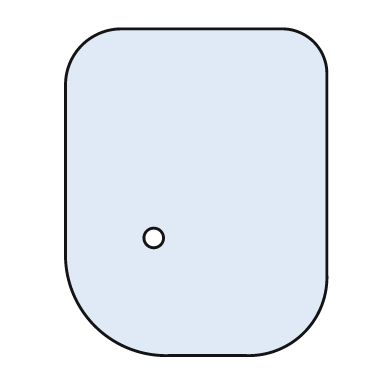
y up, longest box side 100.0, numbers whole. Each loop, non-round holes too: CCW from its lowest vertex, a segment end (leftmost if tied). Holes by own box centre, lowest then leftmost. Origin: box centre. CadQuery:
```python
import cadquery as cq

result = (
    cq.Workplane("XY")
    .moveTo(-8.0, -50.0)
    .lineTo(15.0, -50.0)
    .threePointArc((33.0, -43.0), (40.0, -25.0))
    .lineTo(40.0, 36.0)
    .threePointArc((36.0, 46.0), (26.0, 50.0))
    .lineTo(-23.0, 50.0)
    .threePointArc((-35.0, 45.0), (-40.0, 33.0))
    .lineTo(-40.0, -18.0)
    .threePointArc((-31.0, -41.0), (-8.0, -50.0))
    .close()
    .moveTo(-13.0, -14.0)
    .circle(3.0)
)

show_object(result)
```